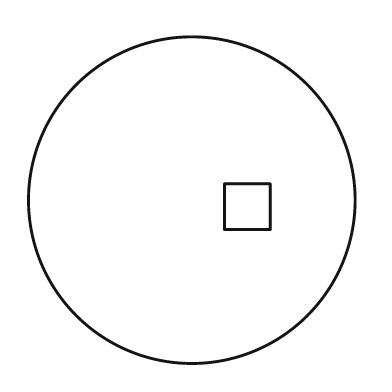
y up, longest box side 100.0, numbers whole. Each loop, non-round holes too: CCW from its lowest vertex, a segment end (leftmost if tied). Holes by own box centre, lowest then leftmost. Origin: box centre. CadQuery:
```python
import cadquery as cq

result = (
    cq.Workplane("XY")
    .moveTo(0.0, 0.0)
    .circle(50.0)
    .moveTo(10.0, -9.0)
    .lineTo(24.0, -9.0)
    .lineTo(24.0, 5.0)
    .lineTo(10.0, 5.0)
    .close()
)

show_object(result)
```